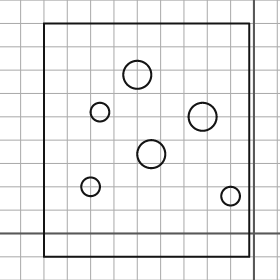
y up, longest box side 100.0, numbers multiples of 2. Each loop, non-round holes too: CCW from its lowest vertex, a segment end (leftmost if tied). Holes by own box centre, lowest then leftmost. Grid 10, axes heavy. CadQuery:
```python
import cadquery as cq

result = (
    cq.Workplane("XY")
    .moveTo(-90.0, -10.0)
    .lineTo(-2.0, -10.0)
    .lineTo(-2.0, 90.0)
    .lineTo(-90.0, 90.0)
    .close()
    .moveTo(-10.0, 16.0)
    .circle(4.0)
    .moveTo(-70.0, 20.0)
    .circle(4.0)
    .moveTo(-44.0, 34.0)
    .circle(6.0)
    .moveTo(-22.0, 50.0)
    .circle(6.0)
    .moveTo(-66.0, 52.0)
    .circle(4.0)
    .moveTo(-50.0, 68.0)
    .circle(6.0)
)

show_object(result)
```